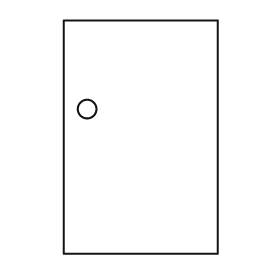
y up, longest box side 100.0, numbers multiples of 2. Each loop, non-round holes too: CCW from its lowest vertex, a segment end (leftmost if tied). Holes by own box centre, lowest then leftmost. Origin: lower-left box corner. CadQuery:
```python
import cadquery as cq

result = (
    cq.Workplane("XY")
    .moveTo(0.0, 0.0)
    .lineTo(66.0, 0.0)
    .lineTo(66.0, 100.0)
    .lineTo(0.0, 100.0)
    .close()
    .moveTo(10.0, 62.0)
    .circle(4.0)
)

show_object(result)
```